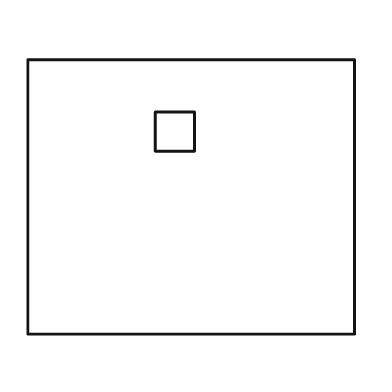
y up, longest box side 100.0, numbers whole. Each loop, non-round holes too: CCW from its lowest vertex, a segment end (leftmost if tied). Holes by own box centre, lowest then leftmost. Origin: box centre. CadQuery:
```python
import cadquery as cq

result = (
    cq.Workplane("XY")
    .moveTo(-50.0, -42.0)
    .lineTo(50.0, -42.0)
    .lineTo(50.0, 42.0)
    .lineTo(-50.0, 42.0)
    .close()
    .moveTo(-11.0, 14.0)
    .lineTo(1.0, 14.0)
    .lineTo(1.0, 26.0)
    .lineTo(-11.0, 26.0)
    .close()
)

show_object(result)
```